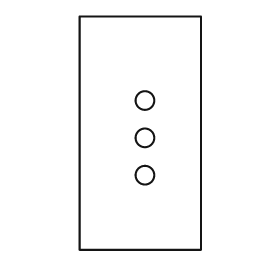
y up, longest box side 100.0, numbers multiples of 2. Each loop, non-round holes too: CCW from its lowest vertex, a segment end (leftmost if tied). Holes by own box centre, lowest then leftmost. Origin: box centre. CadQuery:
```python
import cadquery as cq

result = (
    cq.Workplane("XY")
    .moveTo(-26.0, -50.0)
    .lineTo(26.0, -50.0)
    .lineTo(26.0, 50.0)
    .lineTo(-26.0, 50.0)
    .close()
    .moveTo(2.0, -18.0)
    .circle(4.0)
    .moveTo(2.0, -2.0)
    .circle(4.0)
    .moveTo(2.0, 14.0)
    .circle(4.0)
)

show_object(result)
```